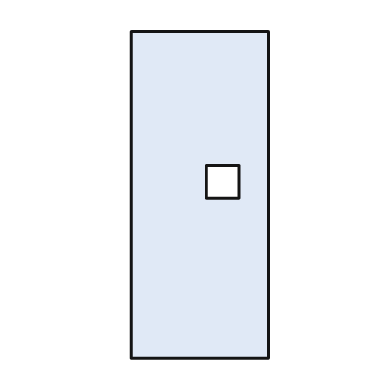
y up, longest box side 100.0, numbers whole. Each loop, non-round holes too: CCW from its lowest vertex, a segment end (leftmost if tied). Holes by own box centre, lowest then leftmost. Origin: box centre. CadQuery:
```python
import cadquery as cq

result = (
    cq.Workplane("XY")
    .moveTo(-21.0, -50.0)
    .lineTo(21.0, -50.0)
    .lineTo(21.0, 50.0)
    .lineTo(-21.0, 50.0)
    .close()
    .moveTo(2.0, -1.0)
    .lineTo(12.0, -1.0)
    .lineTo(12.0, 9.0)
    .lineTo(2.0, 9.0)
    .close()
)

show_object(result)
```